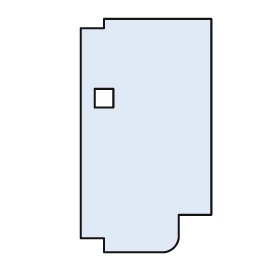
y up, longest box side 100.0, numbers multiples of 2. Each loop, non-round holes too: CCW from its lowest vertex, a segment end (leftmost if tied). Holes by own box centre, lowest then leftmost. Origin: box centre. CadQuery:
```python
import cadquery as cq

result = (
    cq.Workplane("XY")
    .moveTo(-18.0, -50.0)
    .lineTo(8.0, -50.0)
    .threePointArc((12.0, -48.0), (14.0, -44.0))
    .lineTo(14.0, -34.0)
    .lineTo(28.0, -34.0)
    .lineTo(28.0, 50.0)
    .lineTo(-18.0, 50.0)
    .lineTo(-18.0, 46.0)
    .lineTo(-28.0, 46.0)
    .lineTo(-28.0, -44.0)
    .lineTo(-18.0, -44.0)
    .close()
    .moveTo(-22.0, 12.0)
    .lineTo(-14.0, 12.0)
    .lineTo(-14.0, 20.0)
    .lineTo(-22.0, 20.0)
    .close()
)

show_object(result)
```